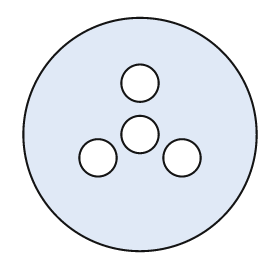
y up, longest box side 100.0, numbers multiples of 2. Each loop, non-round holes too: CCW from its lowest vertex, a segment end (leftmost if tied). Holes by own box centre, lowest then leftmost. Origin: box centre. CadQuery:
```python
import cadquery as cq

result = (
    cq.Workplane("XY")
    .moveTo(0.0, 0.0)
    .circle(50.0)
    .moveTo(-18.0, -10.0)
    .circle(8.0)
    .moveTo(18.0, -10.0)
    .circle(8.0)
    .moveTo(0.0, 0.0)
    .circle(8.0)
    .moveTo(0.0, 22.0)
    .circle(8.0)
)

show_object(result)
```